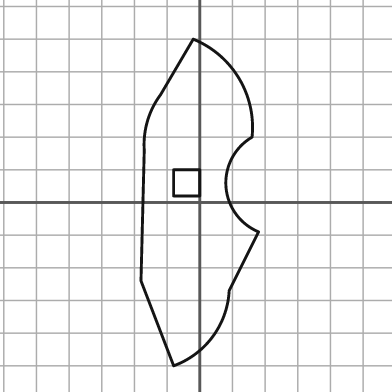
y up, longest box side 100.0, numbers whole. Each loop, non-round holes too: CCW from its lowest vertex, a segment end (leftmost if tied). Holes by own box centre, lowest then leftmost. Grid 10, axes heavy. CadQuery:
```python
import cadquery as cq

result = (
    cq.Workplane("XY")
    .moveTo(-8.0, -50.0)
    .threePointArc((4.0, -41.0), (9.0, -27.0))
    .lineTo(18.0, -9.0)
    .threePointArc((8.0, 5.0), (16.0, 20.0))
    .threePointArc((12.0, 38.0), (-2.0, 50.0))
    .lineTo(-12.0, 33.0)
    .threePointArc((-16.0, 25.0), (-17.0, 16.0))
    .lineTo(-18.0, -24.0)
    .close()
    .moveTo(-8.0, 2.0)
    .lineTo(0.0, 2.0)
    .lineTo(0.0, 10.0)
    .lineTo(-8.0, 10.0)
    .close()
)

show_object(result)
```